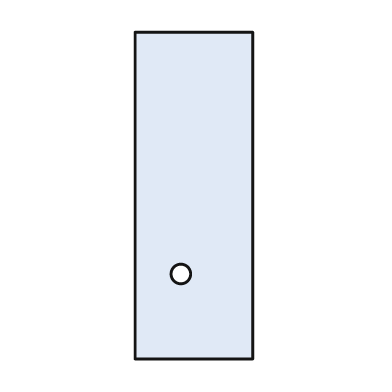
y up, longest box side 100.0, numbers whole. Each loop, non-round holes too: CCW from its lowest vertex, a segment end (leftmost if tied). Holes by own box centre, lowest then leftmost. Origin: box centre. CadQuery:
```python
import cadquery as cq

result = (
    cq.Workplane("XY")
    .moveTo(-18.0, -50.0)
    .lineTo(18.0, -50.0)
    .lineTo(18.0, 50.0)
    .lineTo(-18.0, 50.0)
    .close()
    .moveTo(-4.0, -24.0)
    .circle(3.0)
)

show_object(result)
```